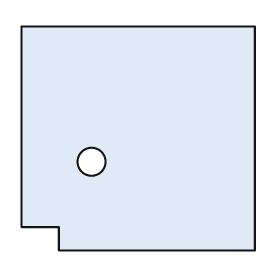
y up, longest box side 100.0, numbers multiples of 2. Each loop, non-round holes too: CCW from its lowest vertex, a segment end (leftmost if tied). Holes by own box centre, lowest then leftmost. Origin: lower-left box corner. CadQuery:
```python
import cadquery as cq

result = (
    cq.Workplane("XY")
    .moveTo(16.0, 0.0)
    .lineTo(100.0, 0.0)
    .lineTo(100.0, 96.0)
    .lineTo(0.0, 96.0)
    .lineTo(0.0, 10.0)
    .lineTo(16.0, 10.0)
    .close()
    .moveTo(30.0, 38.0)
    .circle(6.0)
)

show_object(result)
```